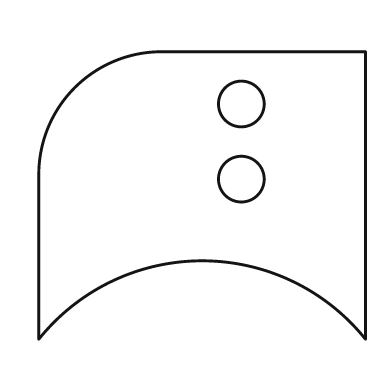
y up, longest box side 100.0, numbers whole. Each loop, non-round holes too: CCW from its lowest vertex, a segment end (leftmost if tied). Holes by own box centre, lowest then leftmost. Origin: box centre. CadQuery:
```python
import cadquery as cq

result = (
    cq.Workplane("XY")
    .moveTo(-50.0, -44.0)
    .threePointArc((0.0, -20.0), (50.0, -44.0))
    .lineTo(50.0, 44.0)
    .lineTo(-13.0, 44.0)
    .threePointArc((-39.0, 33.0), (-50.0, 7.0))
    .close()
    .moveTo(12.0, 5.0)
    .circle(7.0)
    .moveTo(12.0, 28.0)
    .circle(7.0)
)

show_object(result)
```